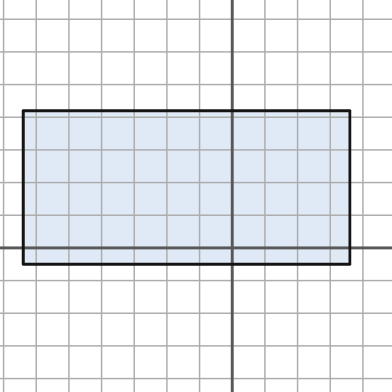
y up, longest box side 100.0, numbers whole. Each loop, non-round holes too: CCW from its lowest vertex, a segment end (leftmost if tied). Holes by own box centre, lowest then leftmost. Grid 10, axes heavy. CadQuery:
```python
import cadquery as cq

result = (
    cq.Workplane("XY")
    .moveTo(-64.0, -5.0)
    .lineTo(36.0, -5.0)
    .lineTo(36.0, 42.0)
    .lineTo(-64.0, 42.0)
    .close()
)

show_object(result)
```